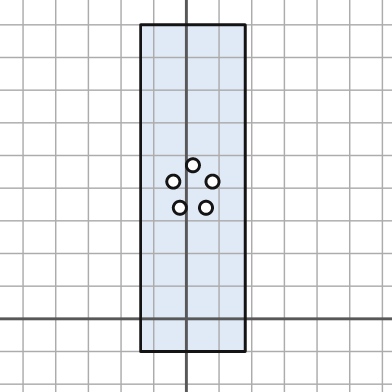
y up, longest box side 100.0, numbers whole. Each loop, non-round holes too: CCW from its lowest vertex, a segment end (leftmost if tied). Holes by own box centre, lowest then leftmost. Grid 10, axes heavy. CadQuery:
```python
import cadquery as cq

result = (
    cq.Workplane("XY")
    .moveTo(-14.0, -10.0)
    .lineTo(18.0, -10.0)
    .lineTo(18.0, 90.0)
    .lineTo(-14.0, 90.0)
    .close()
    .moveTo(-2.0, 34.0)
    .circle(2.0)
    .moveTo(6.0, 34.0)
    .circle(2.0)
    .moveTo(-4.0, 42.0)
    .circle(2.0)
    .moveTo(8.0, 42.0)
    .circle(2.0)
    .moveTo(2.0, 47.0)
    .circle(2.0)
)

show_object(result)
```